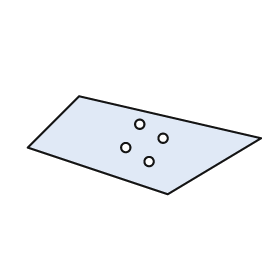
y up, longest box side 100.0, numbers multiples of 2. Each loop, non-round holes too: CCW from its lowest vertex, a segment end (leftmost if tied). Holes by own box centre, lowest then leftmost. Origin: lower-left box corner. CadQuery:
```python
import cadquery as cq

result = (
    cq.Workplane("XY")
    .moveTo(60.0, 0.0)
    .lineTo(100.0, 24.0)
    .lineTo(22.0, 42.0)
    .lineTo(0.0, 20.0)
    .close()
    .moveTo(52.0, 14.0)
    .circle(2.0)
    .moveTo(42.0, 20.0)
    .circle(2.0)
    .moveTo(58.0, 24.0)
    .circle(2.0)
    .moveTo(48.0, 30.0)
    .circle(2.0)
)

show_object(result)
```